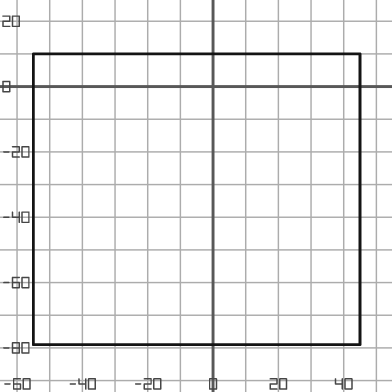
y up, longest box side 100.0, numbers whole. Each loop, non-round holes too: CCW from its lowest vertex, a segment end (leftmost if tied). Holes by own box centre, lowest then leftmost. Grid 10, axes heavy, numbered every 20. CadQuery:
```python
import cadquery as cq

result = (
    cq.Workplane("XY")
    .moveTo(-55.0, -79.0)
    .lineTo(45.0, -79.0)
    .lineTo(45.0, 10.0)
    .lineTo(-55.0, 10.0)
    .close()
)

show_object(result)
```